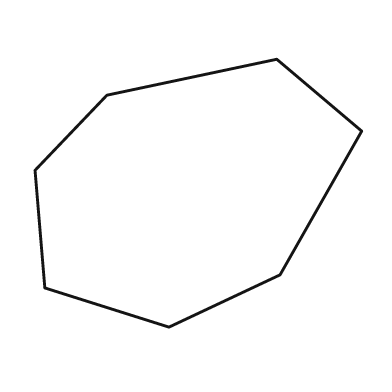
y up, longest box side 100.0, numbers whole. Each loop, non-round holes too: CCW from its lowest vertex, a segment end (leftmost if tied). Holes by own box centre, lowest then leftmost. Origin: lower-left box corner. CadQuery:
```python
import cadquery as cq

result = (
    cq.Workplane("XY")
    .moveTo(41.0, 0.0)
    .lineTo(75.0, 16.0)
    .lineTo(100.0, 60.0)
    .lineTo(74.0, 82.0)
    .lineTo(22.0, 71.0)
    .lineTo(0.0, 48.0)
    .lineTo(3.0, 12.0)
    .close()
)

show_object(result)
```